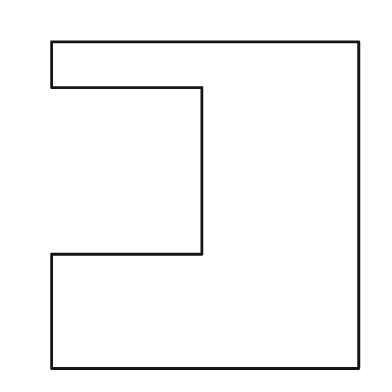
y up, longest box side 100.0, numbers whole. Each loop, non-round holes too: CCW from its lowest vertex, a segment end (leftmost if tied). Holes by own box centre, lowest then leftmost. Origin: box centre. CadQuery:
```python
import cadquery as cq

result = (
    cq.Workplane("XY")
    .moveTo(-47.0, -50.0)
    .lineTo(47.0, -50.0)
    .lineTo(47.0, 50.0)
    .lineTo(-47.0, 50.0)
    .lineTo(-47.0, 36.0)
    .lineTo(-1.0, 36.0)
    .lineTo(-1.0, -15.0)
    .lineTo(-47.0, -15.0)
    .close()
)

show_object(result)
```